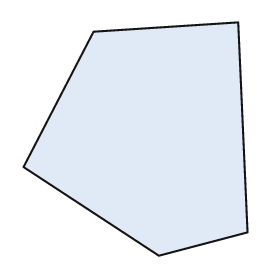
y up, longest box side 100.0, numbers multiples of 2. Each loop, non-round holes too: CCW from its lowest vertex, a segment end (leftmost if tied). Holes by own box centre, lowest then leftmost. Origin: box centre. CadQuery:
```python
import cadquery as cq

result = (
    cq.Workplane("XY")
    .moveTo(10.0, -50.0)
    .lineTo(48.0, -40.0)
    .lineTo(44.0, 50.0)
    .lineTo(-18.0, 46.0)
    .lineTo(-48.0, -12.0)
    .close()
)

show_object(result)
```